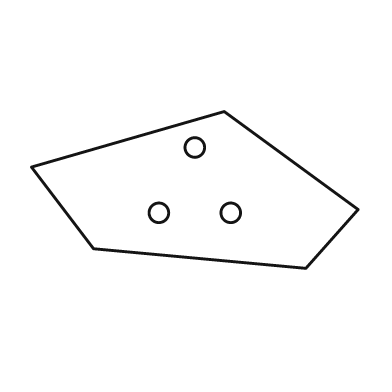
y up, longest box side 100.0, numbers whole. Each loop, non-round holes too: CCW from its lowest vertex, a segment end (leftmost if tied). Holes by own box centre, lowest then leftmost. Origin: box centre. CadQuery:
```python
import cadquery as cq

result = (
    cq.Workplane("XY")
    .moveTo(34.0, -24.0)
    .lineTo(50.0, -6.0)
    .lineTo(9.0, 24.0)
    .lineTo(-50.0, 7.0)
    .lineTo(-31.0, -18.0)
    .close()
    .moveTo(-11.0, -7.0)
    .circle(3.0)
    .moveTo(11.0, -7.0)
    .circle(3.0)
    .moveTo(0.0, 13.0)
    .circle(3.0)
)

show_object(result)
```